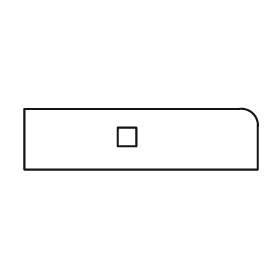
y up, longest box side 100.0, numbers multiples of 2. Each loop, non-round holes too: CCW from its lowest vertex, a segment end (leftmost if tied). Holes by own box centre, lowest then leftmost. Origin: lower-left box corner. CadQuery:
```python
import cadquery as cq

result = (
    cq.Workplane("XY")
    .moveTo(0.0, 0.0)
    .lineTo(100.0, 0.0)
    .lineTo(100.0, 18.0)
    .threePointArc((98.0, 24.0), (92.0, 26.0))
    .lineTo(0.0, 26.0)
    .close()
    .moveTo(40.0, 10.0)
    .lineTo(48.0, 10.0)
    .lineTo(48.0, 18.0)
    .lineTo(40.0, 18.0)
    .close()
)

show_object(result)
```